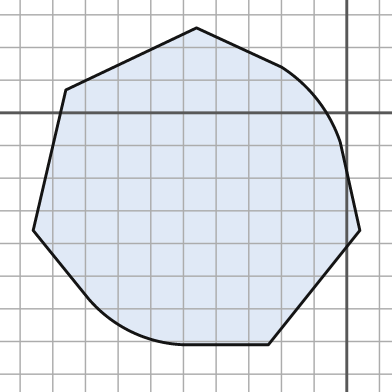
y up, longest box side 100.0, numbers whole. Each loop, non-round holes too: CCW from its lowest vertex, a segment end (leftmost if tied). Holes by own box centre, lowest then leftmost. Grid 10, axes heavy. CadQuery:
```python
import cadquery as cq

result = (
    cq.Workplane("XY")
    .moveTo(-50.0, -71.0)
    .lineTo(-24.0, -71.0)
    .lineTo(4.0, -36.0)
    .lineTo(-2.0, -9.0)
    .threePointArc((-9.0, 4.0), (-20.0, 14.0))
    .lineTo(-46.0, 26.0)
    .lineTo(-86.0, 7.0)
    .lineTo(-96.0, -36.0)
    .lineTo(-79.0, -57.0)
    .threePointArc((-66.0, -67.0), (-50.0, -71.0))
    .close()
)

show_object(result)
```